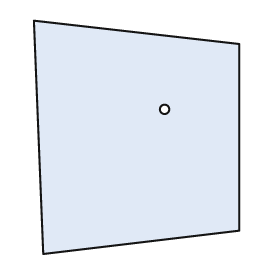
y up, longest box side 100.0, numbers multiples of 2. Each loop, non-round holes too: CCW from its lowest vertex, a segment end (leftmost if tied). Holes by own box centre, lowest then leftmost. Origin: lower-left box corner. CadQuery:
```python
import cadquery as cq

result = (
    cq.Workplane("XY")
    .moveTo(4.0, 0.0)
    .lineTo(88.0, 10.0)
    .lineTo(88.0, 90.0)
    .lineTo(0.0, 100.0)
    .close()
    .moveTo(56.0, 62.0)
    .circle(2.0)
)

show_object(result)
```